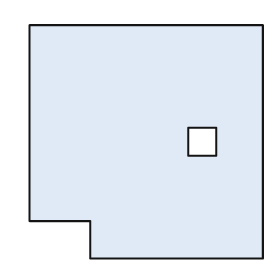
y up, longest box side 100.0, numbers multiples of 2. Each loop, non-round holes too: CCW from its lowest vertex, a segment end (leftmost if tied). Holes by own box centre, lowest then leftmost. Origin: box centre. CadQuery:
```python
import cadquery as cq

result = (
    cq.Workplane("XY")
    .moveTo(-24.0, -50.0)
    .lineTo(50.0, -50.0)
    .lineTo(50.0, 50.0)
    .lineTo(-50.0, 50.0)
    .lineTo(-50.0, -34.0)
    .lineTo(-24.0, -34.0)
    .close()
    .moveTo(18.0, -6.0)
    .lineTo(30.0, -6.0)
    .lineTo(30.0, 6.0)
    .lineTo(18.0, 6.0)
    .close()
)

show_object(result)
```